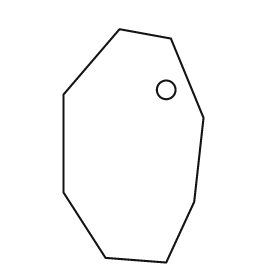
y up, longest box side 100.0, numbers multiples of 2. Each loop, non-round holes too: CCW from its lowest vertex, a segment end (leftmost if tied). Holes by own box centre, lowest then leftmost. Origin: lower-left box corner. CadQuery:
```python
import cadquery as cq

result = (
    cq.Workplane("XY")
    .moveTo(44.0, 0.0)
    .lineTo(56.0, 26.0)
    .lineTo(60.0, 62.0)
    .lineTo(46.0, 96.0)
    .lineTo(24.0, 100.0)
    .lineTo(0.0, 72.0)
    .lineTo(0.0, 30.0)
    .lineTo(18.0, 2.0)
    .close()
    .moveTo(44.0, 74.0)
    .circle(4.0)
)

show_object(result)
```